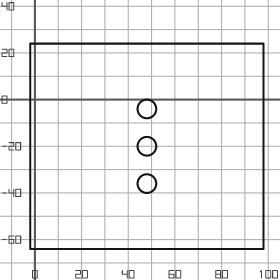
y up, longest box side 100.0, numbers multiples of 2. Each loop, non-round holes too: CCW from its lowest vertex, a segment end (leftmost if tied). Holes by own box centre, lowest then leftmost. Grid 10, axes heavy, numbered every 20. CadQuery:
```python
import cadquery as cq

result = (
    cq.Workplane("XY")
    .moveTo(-2.0, -64.0)
    .lineTo(98.0, -64.0)
    .lineTo(98.0, 24.0)
    .lineTo(-2.0, 24.0)
    .close()
    .moveTo(48.0, -36.0)
    .circle(4.0)
    .moveTo(48.0, -20.0)
    .circle(4.0)
    .moveTo(48.0, -4.0)
    .circle(4.0)
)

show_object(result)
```